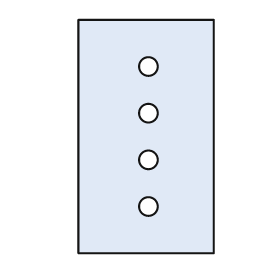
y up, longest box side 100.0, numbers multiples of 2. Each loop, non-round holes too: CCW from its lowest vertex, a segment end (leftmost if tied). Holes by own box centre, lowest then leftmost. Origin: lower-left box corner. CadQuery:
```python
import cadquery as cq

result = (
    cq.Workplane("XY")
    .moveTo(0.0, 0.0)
    .lineTo(58.0, 0.0)
    .lineTo(58.0, 100.0)
    .lineTo(0.0, 100.0)
    .close()
    .moveTo(30.0, 20.0)
    .circle(4.0)
    .moveTo(30.0, 40.0)
    .circle(4.0)
    .moveTo(30.0, 60.0)
    .circle(4.0)
    .moveTo(30.0, 80.0)
    .circle(4.0)
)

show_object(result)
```